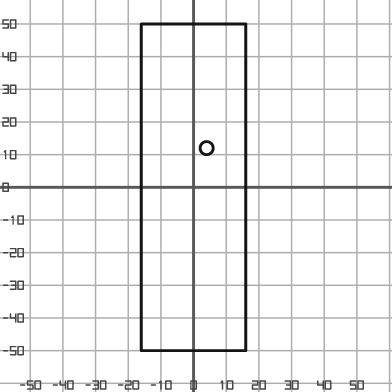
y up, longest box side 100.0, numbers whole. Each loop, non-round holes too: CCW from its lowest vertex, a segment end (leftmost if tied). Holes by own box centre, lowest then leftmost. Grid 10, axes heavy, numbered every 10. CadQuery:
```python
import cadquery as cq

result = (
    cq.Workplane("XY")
    .moveTo(-16.0, -50.0)
    .lineTo(16.0, -50.0)
    .lineTo(16.0, 50.0)
    .lineTo(-16.0, 50.0)
    .close()
    .moveTo(4.0, 12.0)
    .circle(2.0)
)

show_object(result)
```